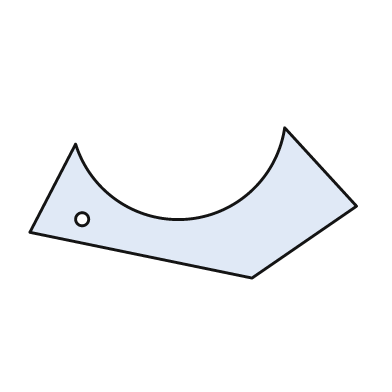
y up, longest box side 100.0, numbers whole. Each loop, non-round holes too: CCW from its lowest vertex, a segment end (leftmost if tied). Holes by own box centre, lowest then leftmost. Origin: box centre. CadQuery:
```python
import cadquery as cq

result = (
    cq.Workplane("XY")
    .moveTo(18.0, -23.0)
    .lineTo(50.0, -1.0)
    .lineTo(28.0, 23.0)
    .threePointArc((-2.0, -5.0), (-36.0, 18.0))
    .lineTo(-50.0, -9.0)
    .close()
    .moveTo(-34.0, -5.0)
    .circle(2.0)
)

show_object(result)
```